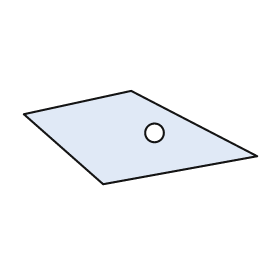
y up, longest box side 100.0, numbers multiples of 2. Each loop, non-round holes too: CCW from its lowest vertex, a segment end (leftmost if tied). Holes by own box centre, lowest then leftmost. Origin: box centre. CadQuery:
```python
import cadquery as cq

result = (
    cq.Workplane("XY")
    .moveTo(-16.0, -20.0)
    .lineTo(50.0, -8.0)
    .lineTo(-4.0, 20.0)
    .lineTo(-50.0, 10.0)
    .close()
    .moveTo(6.0, 2.0)
    .circle(4.0)
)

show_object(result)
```